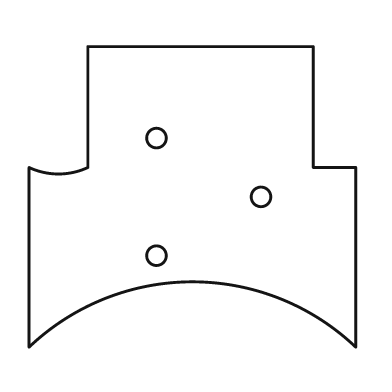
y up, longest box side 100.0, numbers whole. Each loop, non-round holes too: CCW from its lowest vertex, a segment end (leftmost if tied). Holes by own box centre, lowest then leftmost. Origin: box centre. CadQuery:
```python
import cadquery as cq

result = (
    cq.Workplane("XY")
    .moveTo(-50.0, -46.0)
    .threePointArc((0.0, -26.0), (50.0, -46.0))
    .lineTo(50.0, 9.0)
    .lineTo(37.0, 9.0)
    .lineTo(37.0, 46.0)
    .lineTo(-32.0, 46.0)
    .lineTo(-32.0, 9.0)
    .threePointArc((-41.0, 7.0), (-50.0, 9.0))
    .close()
    .moveTo(-11.0, -18.0)
    .circle(3.0)
    .moveTo(21.0, 0.0)
    .circle(3.0)
    .moveTo(-11.0, 18.0)
    .circle(3.0)
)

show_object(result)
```